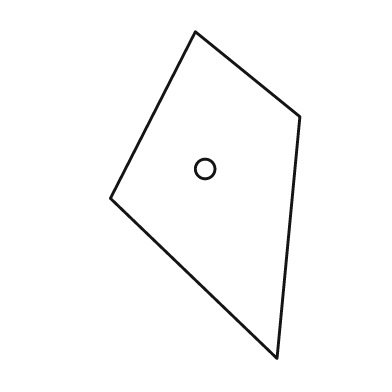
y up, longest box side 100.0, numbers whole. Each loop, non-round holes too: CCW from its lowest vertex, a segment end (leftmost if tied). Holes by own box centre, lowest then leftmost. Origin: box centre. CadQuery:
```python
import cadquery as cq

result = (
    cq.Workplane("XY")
    .moveTo(22.0, -50.0)
    .lineTo(29.0, 24.0)
    .lineTo(-3.0, 50.0)
    .lineTo(-29.0, -1.0)
    .close()
    .moveTo(0.0, 8.0)
    .circle(3.0)
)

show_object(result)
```